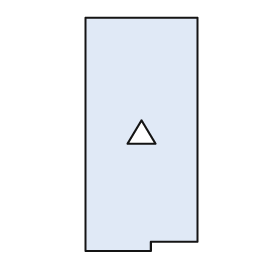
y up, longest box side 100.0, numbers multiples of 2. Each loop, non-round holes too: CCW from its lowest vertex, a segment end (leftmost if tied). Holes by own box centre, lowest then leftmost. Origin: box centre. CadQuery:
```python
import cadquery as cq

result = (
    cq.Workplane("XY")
    .moveTo(-24.0, -50.0)
    .lineTo(4.0, -50.0)
    .lineTo(4.0, -46.0)
    .lineTo(24.0, -46.0)
    .lineTo(24.0, 50.0)
    .lineTo(-24.0, 50.0)
    .close()
    .moveTo(-6.0, -4.0)
    .lineTo(6.0, -4.0)
    .lineTo(0.0, 6.0)
    .close()
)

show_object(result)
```